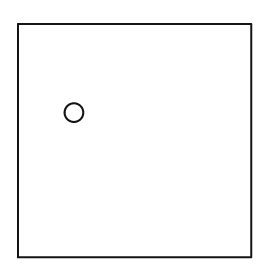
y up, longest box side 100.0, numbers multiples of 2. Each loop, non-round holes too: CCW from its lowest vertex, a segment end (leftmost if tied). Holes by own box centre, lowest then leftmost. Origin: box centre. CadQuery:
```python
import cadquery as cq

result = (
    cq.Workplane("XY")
    .moveTo(-50.0, -50.0)
    .lineTo(50.0, -50.0)
    .lineTo(50.0, 50.0)
    .lineTo(-50.0, 50.0)
    .close()
    .moveTo(-26.0, 12.0)
    .circle(4.0)
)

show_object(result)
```